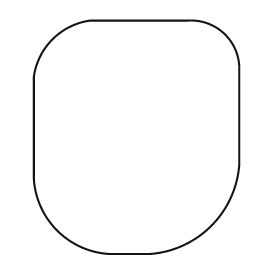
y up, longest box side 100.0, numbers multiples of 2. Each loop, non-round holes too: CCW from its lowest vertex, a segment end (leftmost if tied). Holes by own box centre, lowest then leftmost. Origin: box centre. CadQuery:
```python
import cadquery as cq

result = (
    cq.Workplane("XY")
    .moveTo(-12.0, -50.0)
    .lineTo(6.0, -50.0)
    .threePointArc((32.0, -38.0), (44.0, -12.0))
    .lineTo(44.0, 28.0)
    .threePointArc((38.0, 44.0), (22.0, 50.0))
    .lineTo(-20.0, 50.0)
    .threePointArc((-36.0, 42.0), (-44.0, 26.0))
    .lineTo(-44.0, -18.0)
    .threePointArc((-34.0, -40.0), (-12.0, -50.0))
    .close()
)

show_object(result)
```